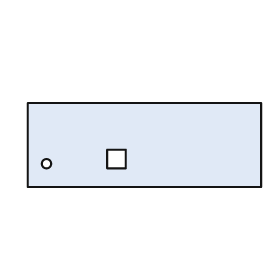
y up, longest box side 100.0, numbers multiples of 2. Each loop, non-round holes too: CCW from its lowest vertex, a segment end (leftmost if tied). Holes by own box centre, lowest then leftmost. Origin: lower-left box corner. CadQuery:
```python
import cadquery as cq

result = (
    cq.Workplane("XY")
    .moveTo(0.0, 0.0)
    .lineTo(100.0, 0.0)
    .lineTo(100.0, 36.0)
    .lineTo(0.0, 36.0)
    .close()
    .moveTo(8.0, 10.0)
    .circle(2.0)
    .moveTo(34.0, 8.0)
    .lineTo(42.0, 8.0)
    .lineTo(42.0, 16.0)
    .lineTo(34.0, 16.0)
    .close()
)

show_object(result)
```